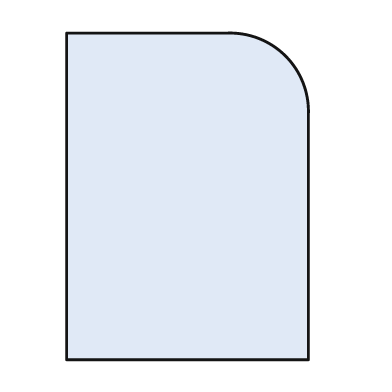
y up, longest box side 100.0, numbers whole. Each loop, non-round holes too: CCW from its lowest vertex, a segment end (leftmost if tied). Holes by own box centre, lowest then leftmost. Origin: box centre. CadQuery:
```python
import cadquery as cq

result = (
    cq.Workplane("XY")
    .moveTo(-37.0, -50.0)
    .lineTo(37.0, -50.0)
    .lineTo(37.0, 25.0)
    .threePointArc((30.0, 43.0), (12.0, 50.0))
    .lineTo(-37.0, 50.0)
    .close()
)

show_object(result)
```